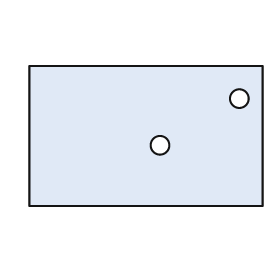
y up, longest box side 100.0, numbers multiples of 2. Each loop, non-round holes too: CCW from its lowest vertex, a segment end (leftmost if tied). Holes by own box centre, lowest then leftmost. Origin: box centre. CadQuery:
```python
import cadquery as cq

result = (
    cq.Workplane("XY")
    .moveTo(-50.0, -30.0)
    .lineTo(50.0, -30.0)
    .lineTo(50.0, 30.0)
    .lineTo(-50.0, 30.0)
    .close()
    .moveTo(6.0, -4.0)
    .circle(4.0)
    .moveTo(40.0, 16.0)
    .circle(4.0)
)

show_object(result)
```